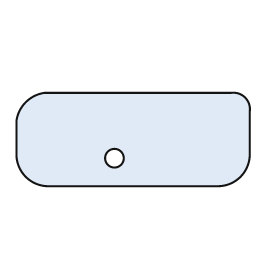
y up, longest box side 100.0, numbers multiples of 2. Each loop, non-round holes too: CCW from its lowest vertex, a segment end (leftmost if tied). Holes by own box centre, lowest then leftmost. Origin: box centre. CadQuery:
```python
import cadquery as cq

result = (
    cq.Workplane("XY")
    .moveTo(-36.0, -20.0)
    .lineTo(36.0, -20.0)
    .threePointArc((46.0, -16.0), (50.0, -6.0))
    .lineTo(50.0, 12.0)
    .threePointArc((48.0, 18.0), (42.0, 20.0))
    .lineTo(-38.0, 20.0)
    .threePointArc((-46.0, 16.0), (-50.0, 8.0))
    .lineTo(-50.0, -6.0)
    .threePointArc((-46.0, -16.0), (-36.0, -20.0))
    .close()
    .moveTo(-8.0, -8.0)
    .circle(4.0)
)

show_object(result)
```